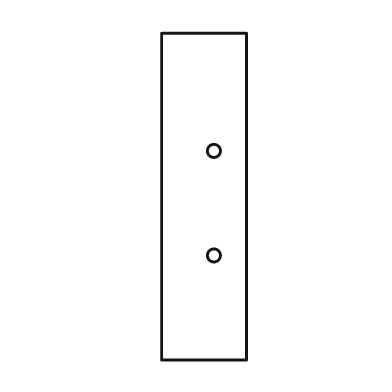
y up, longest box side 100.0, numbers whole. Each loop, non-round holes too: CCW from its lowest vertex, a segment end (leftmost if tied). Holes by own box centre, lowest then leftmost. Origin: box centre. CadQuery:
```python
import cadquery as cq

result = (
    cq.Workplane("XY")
    .moveTo(-13.0, -50.0)
    .lineTo(13.0, -50.0)
    .lineTo(13.0, 50.0)
    .lineTo(-13.0, 50.0)
    .close()
    .moveTo(3.0, -18.0)
    .circle(2.0)
    .moveTo(3.0, 14.0)
    .circle(2.0)
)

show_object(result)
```